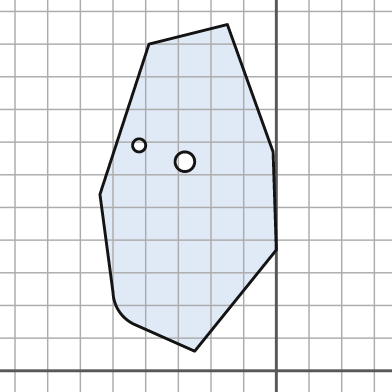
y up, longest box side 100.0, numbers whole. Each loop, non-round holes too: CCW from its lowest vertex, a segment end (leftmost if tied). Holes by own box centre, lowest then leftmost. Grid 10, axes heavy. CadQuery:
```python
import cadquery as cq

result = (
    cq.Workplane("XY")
    .moveTo(-25.0, 6.0)
    .lineTo(0.0, 37.0)
    .lineTo(-1.0, 67.0)
    .lineTo(-15.0, 106.0)
    .lineTo(-39.0, 100.0)
    .lineTo(-54.0, 54.0)
    .lineTo(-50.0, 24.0)
    .threePointArc((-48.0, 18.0), (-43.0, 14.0))
    .close()
    .moveTo(-28.0, 64.0)
    .circle(3.0)
    .moveTo(-42.0, 69.0)
    .circle(2.0)
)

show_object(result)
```